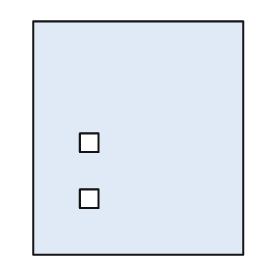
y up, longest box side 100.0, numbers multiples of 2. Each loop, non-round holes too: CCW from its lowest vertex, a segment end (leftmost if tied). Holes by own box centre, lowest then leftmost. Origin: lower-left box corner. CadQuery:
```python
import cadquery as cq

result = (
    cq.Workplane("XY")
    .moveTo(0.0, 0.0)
    .lineTo(90.0, 0.0)
    .lineTo(90.0, 100.0)
    .lineTo(0.0, 100.0)
    .close()
    .moveTo(20.0, 20.0)
    .lineTo(28.0, 20.0)
    .lineTo(28.0, 28.0)
    .lineTo(20.0, 28.0)
    .close()
    .moveTo(20.0, 44.0)
    .lineTo(28.0, 44.0)
    .lineTo(28.0, 52.0)
    .lineTo(20.0, 52.0)
    .close()
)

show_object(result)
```